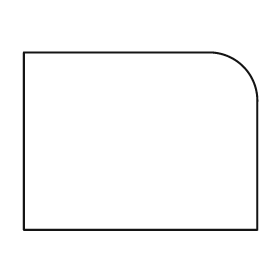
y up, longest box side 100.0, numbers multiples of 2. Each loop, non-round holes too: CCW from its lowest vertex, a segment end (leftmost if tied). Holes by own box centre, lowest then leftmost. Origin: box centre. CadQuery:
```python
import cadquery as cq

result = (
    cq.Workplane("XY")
    .moveTo(-50.0, -38.0)
    .lineTo(50.0, -38.0)
    .lineTo(50.0, 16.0)
    .threePointArc((44.0, 32.0), (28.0, 38.0))
    .lineTo(-50.0, 38.0)
    .close()
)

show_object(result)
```